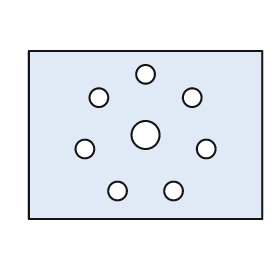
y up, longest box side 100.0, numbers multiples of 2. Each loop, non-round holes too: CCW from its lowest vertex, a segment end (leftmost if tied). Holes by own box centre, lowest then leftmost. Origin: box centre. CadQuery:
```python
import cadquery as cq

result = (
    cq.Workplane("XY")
    .moveTo(-50.0, -36.0)
    .lineTo(50.0, -36.0)
    .lineTo(50.0, 36.0)
    .lineTo(-50.0, 36.0)
    .close()
    .moveTo(-12.0, -24.0)
    .circle(4.0)
    .moveTo(12.0, -24.0)
    .circle(4.0)
    .moveTo(-26.0, -6.0)
    .circle(4.0)
    .moveTo(26.0, -6.0)
    .circle(4.0)
    .moveTo(0.0, 0.0)
    .circle(6.0)
    .moveTo(-20.0, 16.0)
    .circle(4.0)
    .moveTo(20.0, 16.0)
    .circle(4.0)
    .moveTo(0.0, 26.0)
    .circle(4.0)
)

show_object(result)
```